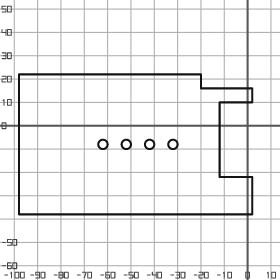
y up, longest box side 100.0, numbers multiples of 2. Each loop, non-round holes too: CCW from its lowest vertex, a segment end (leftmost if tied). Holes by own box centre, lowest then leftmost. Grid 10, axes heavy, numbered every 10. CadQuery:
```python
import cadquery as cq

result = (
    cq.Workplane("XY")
    .moveTo(-98.0, -38.0)
    .lineTo(2.0, -38.0)
    .lineTo(2.0, -22.0)
    .lineTo(-12.0, -22.0)
    .lineTo(-12.0, 10.0)
    .lineTo(2.0, 10.0)
    .lineTo(2.0, 16.0)
    .lineTo(-20.0, 16.0)
    .lineTo(-20.0, 22.0)
    .lineTo(-98.0, 22.0)
    .close()
    .moveTo(-62.0, -8.0)
    .circle(2.0)
    .moveTo(-52.0, -8.0)
    .circle(2.0)
    .moveTo(-42.0, -8.0)
    .circle(2.0)
    .moveTo(-32.0, -8.0)
    .circle(2.0)
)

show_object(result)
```